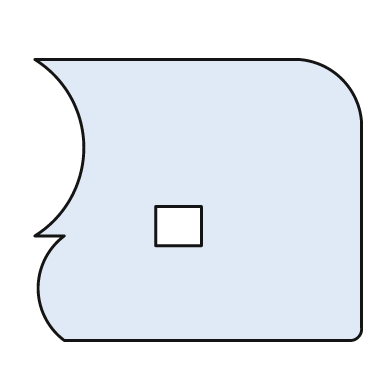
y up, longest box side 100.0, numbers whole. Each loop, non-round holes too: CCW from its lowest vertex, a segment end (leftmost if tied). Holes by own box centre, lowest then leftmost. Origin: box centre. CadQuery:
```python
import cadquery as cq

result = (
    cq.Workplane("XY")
    .moveTo(-41.0, -43.0)
    .lineTo(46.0, -43.0)
    .threePointArc((49.0, -42.0), (50.0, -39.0))
    .lineTo(50.0, 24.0)
    .threePointArc((44.0, 37.0), (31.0, 43.0))
    .lineTo(-50.0, 43.0)
    .threePointArc((-35.0, 16.0), (-50.0, -11.0))
    .lineTo(-41.0, -11.0)
    .threePointArc((-49.0, -27.0), (-41.0, -43.0))
    .close()
    .moveTo(-13.0, -14.0)
    .lineTo(1.0, -14.0)
    .lineTo(1.0, -2.0)
    .lineTo(-13.0, -2.0)
    .close()
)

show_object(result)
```